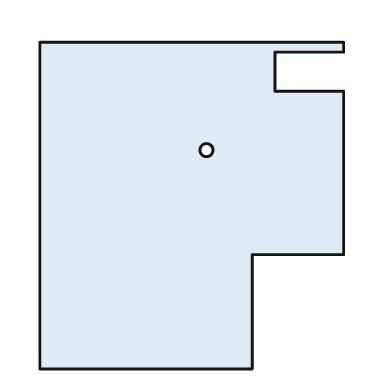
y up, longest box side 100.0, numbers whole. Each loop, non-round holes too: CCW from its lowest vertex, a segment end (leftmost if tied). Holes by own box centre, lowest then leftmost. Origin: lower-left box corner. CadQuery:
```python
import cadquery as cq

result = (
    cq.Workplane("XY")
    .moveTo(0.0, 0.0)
    .lineTo(65.0, 0.0)
    .lineTo(65.0, 35.0)
    .lineTo(93.0, 35.0)
    .lineTo(93.0, 85.0)
    .lineTo(72.0, 85.0)
    .lineTo(72.0, 97.0)
    .lineTo(93.0, 97.0)
    .lineTo(93.0, 100.0)
    .lineTo(0.0, 100.0)
    .close()
    .moveTo(51.0, 67.0)
    .circle(2.0)
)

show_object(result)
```